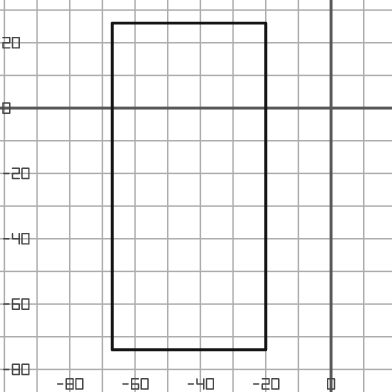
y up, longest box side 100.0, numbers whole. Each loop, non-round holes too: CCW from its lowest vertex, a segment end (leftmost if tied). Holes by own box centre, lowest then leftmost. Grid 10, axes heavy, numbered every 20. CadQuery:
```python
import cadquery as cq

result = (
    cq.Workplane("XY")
    .moveTo(-67.0, -74.0)
    .lineTo(-20.0, -74.0)
    .lineTo(-20.0, 26.0)
    .lineTo(-67.0, 26.0)
    .close()
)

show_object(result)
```